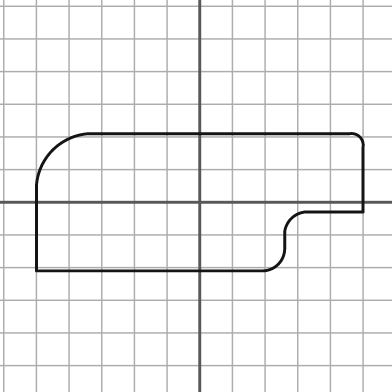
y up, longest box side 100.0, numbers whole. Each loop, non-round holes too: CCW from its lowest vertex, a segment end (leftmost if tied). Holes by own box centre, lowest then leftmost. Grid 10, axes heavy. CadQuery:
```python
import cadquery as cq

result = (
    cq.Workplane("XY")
    .moveTo(-50.0, -21.0)
    .lineTo(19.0, -21.0)
    .threePointArc((24.0, -19.0), (26.0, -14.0))
    .lineTo(26.0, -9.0)
    .threePointArc((28.0, -5.0), (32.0, -3.0))
    .lineTo(50.0, -3.0)
    .lineTo(50.0, 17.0)
    .threePointArc((49.0, 20.0), (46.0, 21.0))
    .lineTo(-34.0, 21.0)
    .threePointArc((-45.0, 16.0), (-50.0, 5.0))
    .close()
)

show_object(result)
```